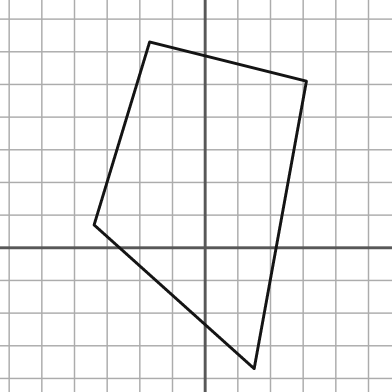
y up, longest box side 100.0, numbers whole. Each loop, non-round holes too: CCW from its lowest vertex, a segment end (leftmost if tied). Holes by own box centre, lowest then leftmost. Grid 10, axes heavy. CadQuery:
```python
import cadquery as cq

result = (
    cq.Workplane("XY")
    .moveTo(15.0, -37.0)
    .lineTo(31.0, 51.0)
    .lineTo(-17.0, 63.0)
    .lineTo(-34.0, 7.0)
    .close()
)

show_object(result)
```